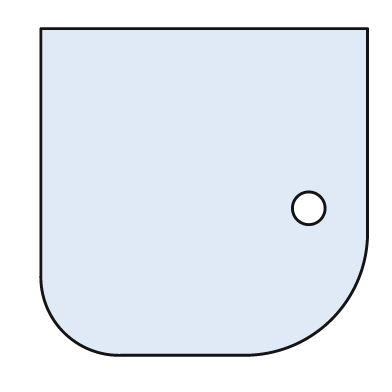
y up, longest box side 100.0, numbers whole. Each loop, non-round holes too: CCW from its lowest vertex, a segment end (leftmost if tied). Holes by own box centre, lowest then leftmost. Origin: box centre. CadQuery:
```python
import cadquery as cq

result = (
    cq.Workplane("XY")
    .moveTo(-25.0, -50.0)
    .lineTo(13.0, -50.0)
    .threePointArc((39.0, -39.0), (50.0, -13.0))
    .lineTo(50.0, 50.0)
    .lineTo(-50.0, 50.0)
    .lineTo(-50.0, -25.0)
    .threePointArc((-43.0, -43.0), (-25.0, -50.0))
    .close()
    .moveTo(32.0, -5.0)
    .circle(5.0)
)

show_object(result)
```